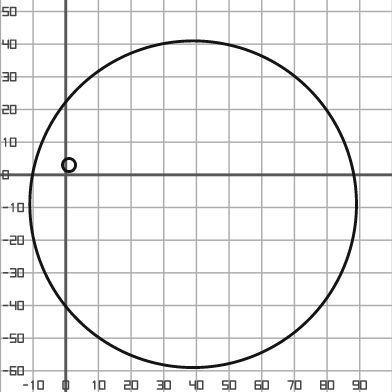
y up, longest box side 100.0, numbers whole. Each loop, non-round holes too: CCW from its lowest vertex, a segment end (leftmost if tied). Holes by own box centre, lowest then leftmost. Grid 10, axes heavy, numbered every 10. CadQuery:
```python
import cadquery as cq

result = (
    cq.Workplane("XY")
    .moveTo(39.0, -9.0)
    .circle(50.0)
    .moveTo(1.0, 3.0)
    .circle(2.0)
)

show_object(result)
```